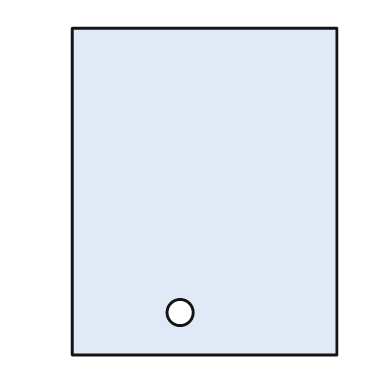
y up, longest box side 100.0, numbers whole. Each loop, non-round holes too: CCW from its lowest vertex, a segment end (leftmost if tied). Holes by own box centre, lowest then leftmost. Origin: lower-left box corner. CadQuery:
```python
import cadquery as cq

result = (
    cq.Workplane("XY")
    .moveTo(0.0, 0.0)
    .lineTo(81.0, 0.0)
    .lineTo(81.0, 100.0)
    .lineTo(0.0, 100.0)
    .close()
    .moveTo(33.0, 13.0)
    .circle(4.0)
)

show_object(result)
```